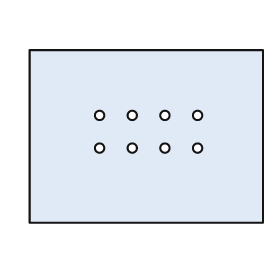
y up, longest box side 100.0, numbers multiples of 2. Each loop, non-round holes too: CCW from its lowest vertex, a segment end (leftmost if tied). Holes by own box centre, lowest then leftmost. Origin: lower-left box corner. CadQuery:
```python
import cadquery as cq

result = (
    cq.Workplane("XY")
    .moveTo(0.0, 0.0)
    .lineTo(100.0, 0.0)
    .lineTo(100.0, 74.0)
    .lineTo(0.0, 74.0)
    .close()
    .moveTo(30.0, 32.0)
    .circle(2.0)
    .moveTo(44.0, 32.0)
    .circle(2.0)
    .moveTo(58.0, 32.0)
    .circle(2.0)
    .moveTo(72.0, 32.0)
    .circle(2.0)
    .moveTo(30.0, 46.0)
    .circle(2.0)
    .moveTo(44.0, 46.0)
    .circle(2.0)
    .moveTo(58.0, 46.0)
    .circle(2.0)
    .moveTo(72.0, 46.0)
    .circle(2.0)
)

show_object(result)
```